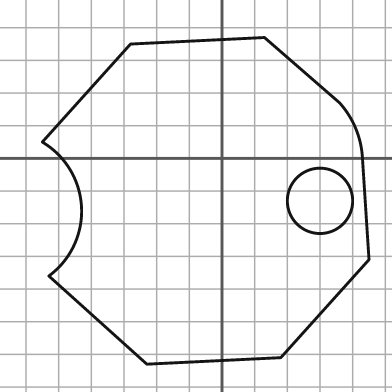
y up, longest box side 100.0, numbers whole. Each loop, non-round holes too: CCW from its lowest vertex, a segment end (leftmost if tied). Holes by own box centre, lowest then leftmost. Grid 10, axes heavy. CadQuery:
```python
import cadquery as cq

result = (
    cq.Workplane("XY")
    .moveTo(-23.0, -63.0)
    .lineTo(18.0, -61.0)
    .lineTo(45.0, -31.0)
    .lineTo(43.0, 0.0)
    .threePointArc((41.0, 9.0), (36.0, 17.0))
    .lineTo(13.0, 37.0)
    .lineTo(-28.0, 35.0)
    .lineTo(-55.0, 5.0)
    .threePointArc((-43.0, -15.0), (-53.0, -36.0))
    .close()
    .moveTo(30.0, -13.0)
    .circle(10.0)
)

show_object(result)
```